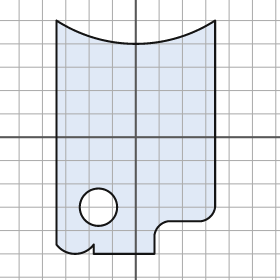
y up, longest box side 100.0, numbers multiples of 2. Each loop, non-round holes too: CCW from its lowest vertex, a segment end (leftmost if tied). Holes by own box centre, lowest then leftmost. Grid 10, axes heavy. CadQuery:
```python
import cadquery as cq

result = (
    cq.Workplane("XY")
    .moveTo(-18.0, -50.0)
    .lineTo(8.0, -50.0)
    .lineTo(8.0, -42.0)
    .threePointArc((10.0, -38.0), (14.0, -36.0))
    .lineTo(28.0, -36.0)
    .threePointArc((32.0, -34.0), (34.0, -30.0))
    .lineTo(34.0, 50.0)
    .threePointArc((0.0, 40.0), (-34.0, 50.0))
    .lineTo(-34.0, -46.0)
    .threePointArc((-26.0, -50.0), (-18.0, -46.0))
    .close()
    .moveTo(-16.0, -30.0)
    .circle(8.0)
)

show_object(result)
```